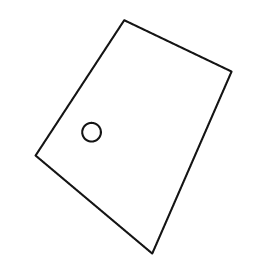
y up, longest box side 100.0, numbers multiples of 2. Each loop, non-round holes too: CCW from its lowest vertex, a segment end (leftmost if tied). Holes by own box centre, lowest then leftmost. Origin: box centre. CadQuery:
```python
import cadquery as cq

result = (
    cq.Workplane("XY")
    .moveTo(8.0, -50.0)
    .lineTo(42.0, 28.0)
    .lineTo(-4.0, 50.0)
    .lineTo(-42.0, -8.0)
    .close()
    .moveTo(-18.0, 2.0)
    .circle(4.0)
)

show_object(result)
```